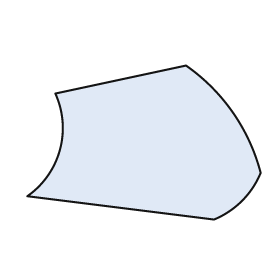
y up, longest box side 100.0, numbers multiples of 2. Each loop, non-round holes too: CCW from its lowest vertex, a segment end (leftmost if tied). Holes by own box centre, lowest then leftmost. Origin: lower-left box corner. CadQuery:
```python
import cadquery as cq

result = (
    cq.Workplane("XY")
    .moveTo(80.0, 0.0)
    .threePointArc((92.0, 8.0), (100.0, 20.0))
    .threePointArc((88.0, 46.0), (68.0, 66.0))
    .lineTo(12.0, 54.0)
    .threePointArc((14.0, 30.0), (0.0, 10.0))
    .close()
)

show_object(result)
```